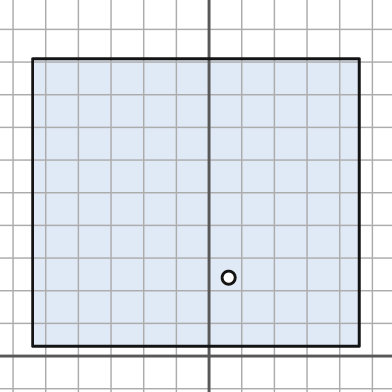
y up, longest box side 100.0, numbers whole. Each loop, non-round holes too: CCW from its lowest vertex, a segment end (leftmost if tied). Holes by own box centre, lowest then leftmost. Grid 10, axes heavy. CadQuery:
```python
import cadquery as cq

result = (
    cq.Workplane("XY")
    .moveTo(-54.0, 3.0)
    .lineTo(46.0, 3.0)
    .lineTo(46.0, 91.0)
    .lineTo(-54.0, 91.0)
    .close()
    .moveTo(6.0, 24.0)
    .circle(2.0)
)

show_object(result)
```